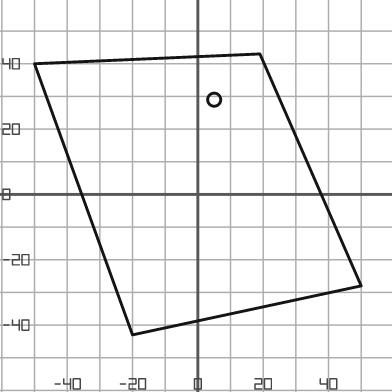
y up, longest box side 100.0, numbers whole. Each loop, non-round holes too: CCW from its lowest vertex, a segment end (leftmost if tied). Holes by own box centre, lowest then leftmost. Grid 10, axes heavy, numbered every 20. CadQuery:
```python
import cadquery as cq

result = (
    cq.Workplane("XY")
    .moveTo(-20.0, -43.0)
    .lineTo(50.0, -28.0)
    .lineTo(19.0, 43.0)
    .lineTo(-50.0, 40.0)
    .close()
    .moveTo(5.0, 29.0)
    .circle(2.0)
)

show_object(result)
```